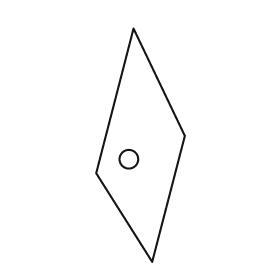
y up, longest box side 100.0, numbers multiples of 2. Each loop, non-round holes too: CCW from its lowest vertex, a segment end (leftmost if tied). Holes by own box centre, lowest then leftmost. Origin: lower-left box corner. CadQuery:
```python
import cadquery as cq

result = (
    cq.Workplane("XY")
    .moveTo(24.0, 0.0)
    .lineTo(38.0, 54.0)
    .lineTo(16.0, 100.0)
    .lineTo(0.0, 38.0)
    .close()
    .moveTo(14.0, 44.0)
    .circle(4.0)
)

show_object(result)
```